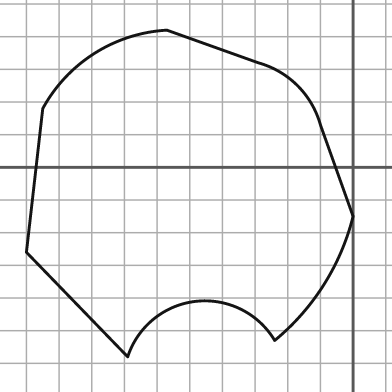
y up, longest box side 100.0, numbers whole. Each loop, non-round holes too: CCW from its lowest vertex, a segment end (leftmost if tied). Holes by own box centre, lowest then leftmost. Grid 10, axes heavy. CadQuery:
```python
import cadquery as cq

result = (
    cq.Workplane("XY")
    .moveTo(-69.0, -58.0)
    .threePointArc((-48.0, -41.0), (-24.0, -53.0))
    .threePointArc((-9.0, -36.0), (0.0, -15.0))
    .lineTo(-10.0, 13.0)
    .threePointArc((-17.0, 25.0), (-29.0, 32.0))
    .lineTo(-57.0, 42.0)
    .threePointArc((-79.0, 35.0), (-95.0, 18.0))
    .lineTo(-100.0, -26.0)
    .close()
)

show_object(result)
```